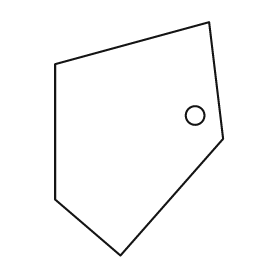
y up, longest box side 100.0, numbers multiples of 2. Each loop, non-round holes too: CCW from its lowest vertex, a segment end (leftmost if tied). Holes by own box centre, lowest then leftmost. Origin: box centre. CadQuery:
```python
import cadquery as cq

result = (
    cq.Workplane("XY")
    .moveTo(-8.0, -50.0)
    .lineTo(36.0, 0.0)
    .lineTo(30.0, 50.0)
    .lineTo(-36.0, 32.0)
    .lineTo(-36.0, -26.0)
    .close()
    .moveTo(24.0, 10.0)
    .circle(4.0)
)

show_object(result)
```